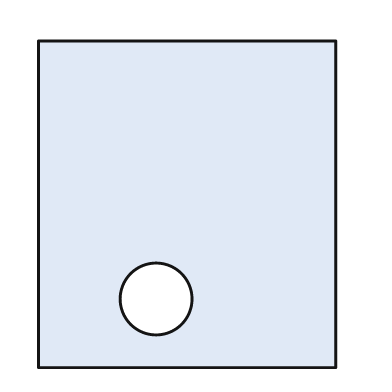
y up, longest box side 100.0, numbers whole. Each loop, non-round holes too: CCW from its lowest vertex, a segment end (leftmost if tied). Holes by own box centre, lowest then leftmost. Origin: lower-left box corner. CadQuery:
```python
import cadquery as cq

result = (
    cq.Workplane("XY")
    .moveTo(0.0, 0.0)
    .lineTo(91.0, 0.0)
    .lineTo(91.0, 100.0)
    .lineTo(0.0, 100.0)
    .close()
    .moveTo(36.0, 21.0)
    .circle(11.0)
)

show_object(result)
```